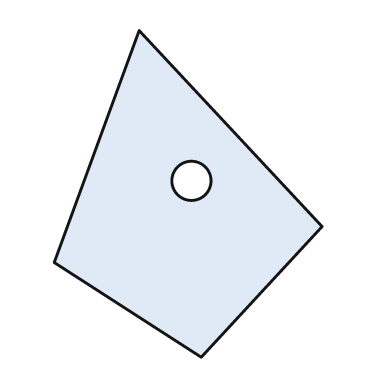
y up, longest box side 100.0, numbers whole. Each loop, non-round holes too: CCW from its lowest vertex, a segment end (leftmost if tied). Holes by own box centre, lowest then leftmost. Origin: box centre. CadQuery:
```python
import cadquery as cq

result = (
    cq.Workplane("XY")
    .moveTo(4.0, -50.0)
    .lineTo(41.0, -10.0)
    .lineTo(-15.0, 50.0)
    .lineTo(-41.0, -21.0)
    .close()
    .moveTo(1.0, 4.0)
    .circle(6.0)
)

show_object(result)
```